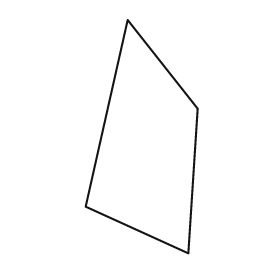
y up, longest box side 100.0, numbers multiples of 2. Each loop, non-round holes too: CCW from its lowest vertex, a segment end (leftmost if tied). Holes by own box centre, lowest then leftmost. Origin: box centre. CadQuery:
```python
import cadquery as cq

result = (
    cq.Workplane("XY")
    .moveTo(20.0, -50.0)
    .lineTo(24.0, 12.0)
    .lineTo(-6.0, 50.0)
    .lineTo(-24.0, -30.0)
    .close()
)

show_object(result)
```